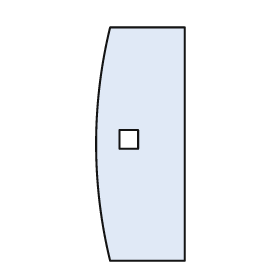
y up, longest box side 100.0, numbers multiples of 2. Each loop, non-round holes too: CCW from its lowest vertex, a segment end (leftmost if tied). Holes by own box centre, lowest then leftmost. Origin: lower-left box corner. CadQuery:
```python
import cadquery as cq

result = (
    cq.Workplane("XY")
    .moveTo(6.0, 0.0)
    .lineTo(38.0, 0.0)
    .lineTo(38.0, 100.0)
    .lineTo(6.0, 100.0)
    .threePointArc((0.0, 50.0), (6.0, 0.0))
    .close()
    .moveTo(10.0, 48.0)
    .lineTo(18.0, 48.0)
    .lineTo(18.0, 56.0)
    .lineTo(10.0, 56.0)
    .close()
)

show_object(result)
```